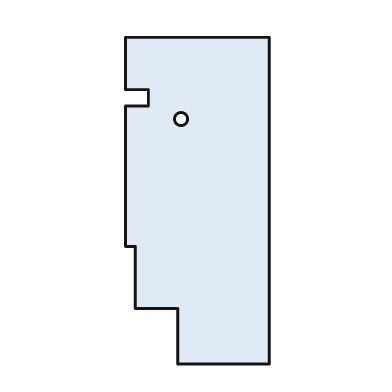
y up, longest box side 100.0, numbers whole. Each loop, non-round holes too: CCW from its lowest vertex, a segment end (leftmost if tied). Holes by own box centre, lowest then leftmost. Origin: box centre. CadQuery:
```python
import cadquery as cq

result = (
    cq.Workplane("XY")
    .moveTo(-6.0, -50.0)
    .lineTo(22.0, -50.0)
    .lineTo(22.0, 50.0)
    .lineTo(-22.0, 50.0)
    .lineTo(-22.0, 34.0)
    .lineTo(-15.0, 34.0)
    .lineTo(-15.0, 29.0)
    .lineTo(-22.0, 29.0)
    .lineTo(-22.0, -14.0)
    .lineTo(-19.0, -14.0)
    .lineTo(-19.0, -33.0)
    .lineTo(-6.0, -33.0)
    .close()
    .moveTo(-5.0, 25.0)
    .circle(2.0)
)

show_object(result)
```